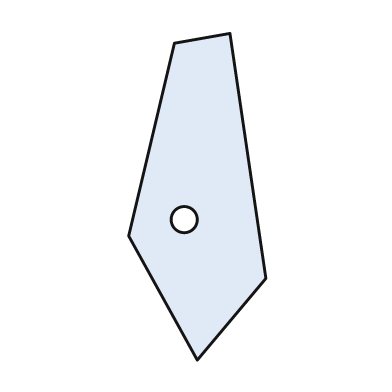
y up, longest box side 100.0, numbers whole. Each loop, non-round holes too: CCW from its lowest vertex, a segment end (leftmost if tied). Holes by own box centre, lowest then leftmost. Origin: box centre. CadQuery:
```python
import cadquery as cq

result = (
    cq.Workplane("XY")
    .moveTo(0.0, -50.0)
    .lineTo(21.0, -25.0)
    .lineTo(10.0, 50.0)
    .lineTo(-7.0, 47.0)
    .lineTo(-21.0, -12.0)
    .close()
    .moveTo(-4.0, -7.0)
    .circle(4.0)
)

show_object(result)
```